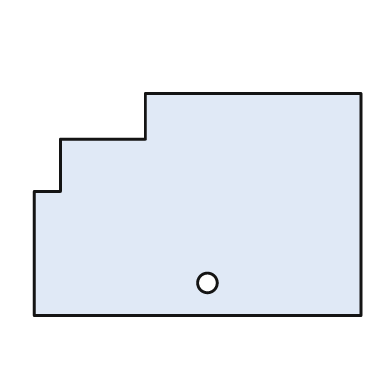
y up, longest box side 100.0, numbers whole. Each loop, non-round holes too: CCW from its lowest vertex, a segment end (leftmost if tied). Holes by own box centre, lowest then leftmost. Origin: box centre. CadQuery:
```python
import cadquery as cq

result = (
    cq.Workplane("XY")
    .moveTo(-50.0, -34.0)
    .lineTo(50.0, -34.0)
    .lineTo(50.0, 34.0)
    .lineTo(-16.0, 34.0)
    .lineTo(-16.0, 20.0)
    .lineTo(-42.0, 20.0)
    .lineTo(-42.0, 4.0)
    .lineTo(-50.0, 4.0)
    .close()
    .moveTo(3.0, -24.0)
    .circle(3.0)
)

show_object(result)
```